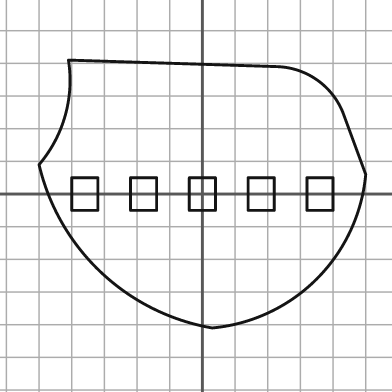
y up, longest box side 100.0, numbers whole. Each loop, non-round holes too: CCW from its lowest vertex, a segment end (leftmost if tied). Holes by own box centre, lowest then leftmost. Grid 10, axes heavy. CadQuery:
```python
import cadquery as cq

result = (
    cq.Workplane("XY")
    .moveTo(3.0, -41.0)
    .threePointArc((35.0, -26.0), (50.0, 6.0))
    .lineTo(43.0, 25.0)
    .threePointArc((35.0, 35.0), (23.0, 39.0))
    .lineTo(-41.0, 41.0)
    .threePointArc((-42.0, 24.0), (-50.0, 9.0))
    .threePointArc((-31.0, -24.0), (3.0, -41.0))
    .close()
    .moveTo(-40.0, -5.0)
    .lineTo(-32.0, -5.0)
    .lineTo(-32.0, 5.0)
    .lineTo(-40.0, 5.0)
    .close()
    .moveTo(-22.0, -5.0)
    .lineTo(-14.0, -5.0)
    .lineTo(-14.0, 5.0)
    .lineTo(-22.0, 5.0)
    .close()
    .moveTo(-4.0, -5.0)
    .lineTo(4.0, -5.0)
    .lineTo(4.0, 5.0)
    .lineTo(-4.0, 5.0)
    .close()
    .moveTo(14.0, -5.0)
    .lineTo(22.0, -5.0)
    .lineTo(22.0, 5.0)
    .lineTo(14.0, 5.0)
    .close()
    .moveTo(32.0, -5.0)
    .lineTo(40.0, -5.0)
    .lineTo(40.0, 5.0)
    .lineTo(32.0, 5.0)
    .close()
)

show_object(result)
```